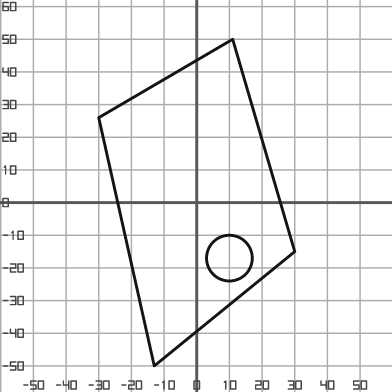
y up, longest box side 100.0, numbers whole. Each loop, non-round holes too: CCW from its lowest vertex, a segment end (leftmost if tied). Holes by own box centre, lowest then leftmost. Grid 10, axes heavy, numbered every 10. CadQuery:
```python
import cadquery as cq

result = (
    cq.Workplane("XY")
    .moveTo(-13.0, -50.0)
    .lineTo(30.0, -15.0)
    .lineTo(11.0, 50.0)
    .lineTo(-30.0, 26.0)
    .close()
    .moveTo(10.0, -17.0)
    .circle(7.0)
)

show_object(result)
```